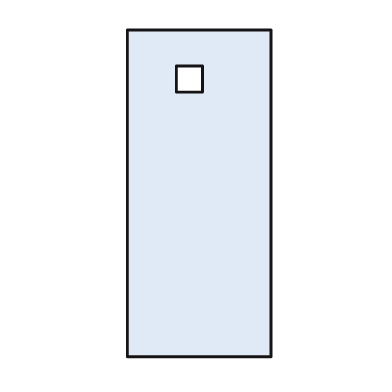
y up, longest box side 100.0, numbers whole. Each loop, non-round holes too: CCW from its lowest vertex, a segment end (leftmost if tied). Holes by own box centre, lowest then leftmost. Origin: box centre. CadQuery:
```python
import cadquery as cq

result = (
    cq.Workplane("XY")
    .moveTo(-22.0, -50.0)
    .lineTo(22.0, -50.0)
    .lineTo(22.0, 50.0)
    .lineTo(-22.0, 50.0)
    .close()
    .moveTo(-7.0, 31.0)
    .lineTo(1.0, 31.0)
    .lineTo(1.0, 39.0)
    .lineTo(-7.0, 39.0)
    .close()
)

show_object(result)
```